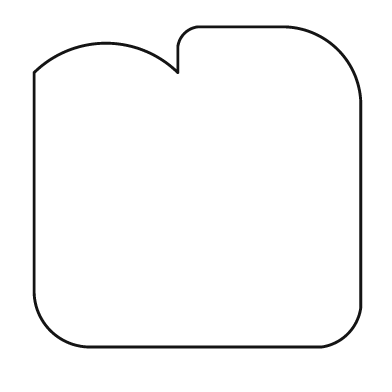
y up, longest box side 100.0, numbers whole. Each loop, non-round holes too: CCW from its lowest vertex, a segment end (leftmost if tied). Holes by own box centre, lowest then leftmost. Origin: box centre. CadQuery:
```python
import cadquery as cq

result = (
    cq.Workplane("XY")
    .moveTo(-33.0, -49.0)
    .lineTo(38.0, -49.0)
    .threePointArc((46.0, -45.0), (50.0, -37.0))
    .lineTo(50.0, 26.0)
    .threePointArc((43.0, 42.0), (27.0, 49.0))
    .lineTo(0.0, 49.0)
    .threePointArc((-4.0, 47.0), (-6.0, 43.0))
    .lineTo(-6.0, 35.0)
    .threePointArc((-28.0, 44.0), (-50.0, 35.0))
    .lineTo(-50.0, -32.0)
    .threePointArc((-45.0, -44.0), (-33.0, -49.0))
    .close()
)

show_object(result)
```